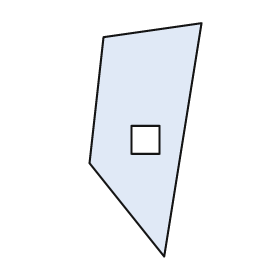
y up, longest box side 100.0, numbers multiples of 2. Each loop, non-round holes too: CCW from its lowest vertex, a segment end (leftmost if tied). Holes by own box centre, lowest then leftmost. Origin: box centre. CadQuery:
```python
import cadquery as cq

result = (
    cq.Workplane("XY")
    .moveTo(8.0, -50.0)
    .lineTo(24.0, 50.0)
    .lineTo(-18.0, 44.0)
    .lineTo(-24.0, -10.0)
    .close()
    .moveTo(-6.0, -6.0)
    .lineTo(6.0, -6.0)
    .lineTo(6.0, 6.0)
    .lineTo(-6.0, 6.0)
    .close()
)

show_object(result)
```